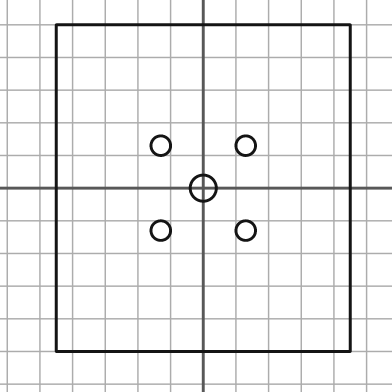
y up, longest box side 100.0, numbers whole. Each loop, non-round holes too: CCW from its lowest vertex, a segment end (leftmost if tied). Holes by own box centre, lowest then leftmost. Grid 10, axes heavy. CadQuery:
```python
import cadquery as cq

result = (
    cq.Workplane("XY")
    .moveTo(-45.0, -50.0)
    .lineTo(45.0, -50.0)
    .lineTo(45.0, 50.0)
    .lineTo(-45.0, 50.0)
    .close()
    .moveTo(-13.0, -13.0)
    .circle(3.0)
    .moveTo(13.0, -13.0)
    .circle(3.0)
    .moveTo(0.0, 0.0)
    .circle(4.0)
    .moveTo(-13.0, 13.0)
    .circle(3.0)
    .moveTo(13.0, 13.0)
    .circle(3.0)
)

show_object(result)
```